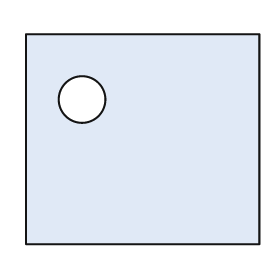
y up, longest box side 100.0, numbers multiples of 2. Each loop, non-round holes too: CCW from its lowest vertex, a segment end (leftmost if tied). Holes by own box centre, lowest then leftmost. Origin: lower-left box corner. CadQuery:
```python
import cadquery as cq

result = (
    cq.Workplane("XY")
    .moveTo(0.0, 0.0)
    .lineTo(100.0, 0.0)
    .lineTo(100.0, 90.0)
    .lineTo(0.0, 90.0)
    .close()
    .moveTo(24.0, 62.0)
    .circle(10.0)
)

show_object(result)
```